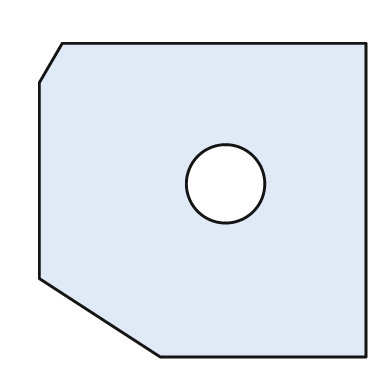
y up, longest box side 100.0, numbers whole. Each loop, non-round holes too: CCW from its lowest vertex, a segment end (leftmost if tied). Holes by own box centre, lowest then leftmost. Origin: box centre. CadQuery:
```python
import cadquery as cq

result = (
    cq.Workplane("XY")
    .moveTo(-13.0, -48.0)
    .lineTo(50.0, -48.0)
    .lineTo(50.0, 48.0)
    .lineTo(-43.0, 48.0)
    .lineTo(-50.0, 36.0)
    .lineTo(-50.0, -24.0)
    .close()
    .moveTo(7.0, 5.0)
    .circle(12.0)
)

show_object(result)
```